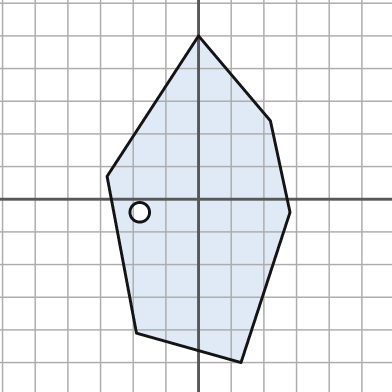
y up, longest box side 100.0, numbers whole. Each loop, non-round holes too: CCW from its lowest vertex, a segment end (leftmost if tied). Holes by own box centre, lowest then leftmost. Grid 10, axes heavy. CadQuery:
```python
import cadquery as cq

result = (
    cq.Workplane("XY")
    .moveTo(13.0, -50.0)
    .lineTo(28.0, -4.0)
    .lineTo(22.0, 24.0)
    .lineTo(0.0, 50.0)
    .lineTo(-28.0, 7.0)
    .lineTo(-19.0, -41.0)
    .close()
    .moveTo(-18.0, -4.0)
    .circle(3.0)
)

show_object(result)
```